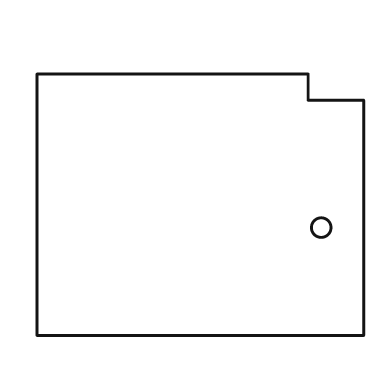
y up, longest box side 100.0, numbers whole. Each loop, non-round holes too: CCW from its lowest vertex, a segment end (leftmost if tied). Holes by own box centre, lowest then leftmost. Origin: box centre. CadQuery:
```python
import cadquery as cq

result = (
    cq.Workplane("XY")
    .moveTo(-50.0, -40.0)
    .lineTo(50.0, -40.0)
    .lineTo(50.0, 32.0)
    .lineTo(33.0, 32.0)
    .lineTo(33.0, 40.0)
    .lineTo(-50.0, 40.0)
    .close()
    .moveTo(37.0, -7.0)
    .circle(3.0)
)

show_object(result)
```